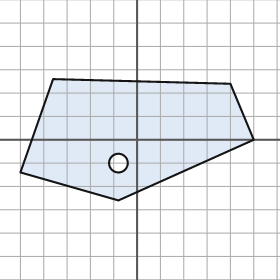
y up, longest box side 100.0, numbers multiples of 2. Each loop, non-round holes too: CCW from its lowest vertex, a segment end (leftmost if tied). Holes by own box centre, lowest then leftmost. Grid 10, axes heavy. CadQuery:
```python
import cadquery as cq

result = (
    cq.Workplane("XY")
    .moveTo(-8.0, -26.0)
    .lineTo(50.0, 0.0)
    .lineTo(40.0, 24.0)
    .lineTo(-36.0, 26.0)
    .lineTo(-50.0, -14.0)
    .close()
    .moveTo(-8.0, -10.0)
    .circle(4.0)
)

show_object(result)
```